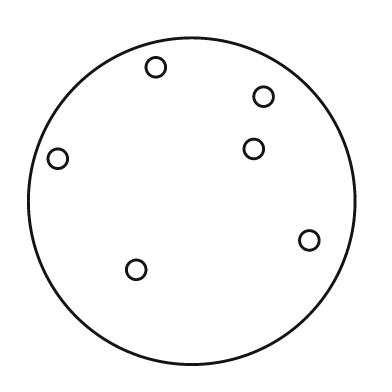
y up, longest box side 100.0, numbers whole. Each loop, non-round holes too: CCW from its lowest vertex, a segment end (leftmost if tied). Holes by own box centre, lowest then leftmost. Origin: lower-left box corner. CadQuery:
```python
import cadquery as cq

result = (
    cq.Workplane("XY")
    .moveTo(50.0, 50.0)
    .circle(50.0)
    .moveTo(33.0, 29.0)
    .circle(3.0)
    .moveTo(86.0, 38.0)
    .circle(3.0)
    .moveTo(9.0, 63.0)
    .circle(3.0)
    .moveTo(69.0, 66.0)
    .circle(3.0)
    .moveTo(72.0, 82.0)
    .circle(3.0)
    .moveTo(39.0, 91.0)
    .circle(3.0)
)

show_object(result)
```